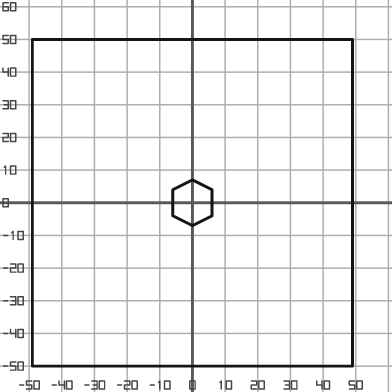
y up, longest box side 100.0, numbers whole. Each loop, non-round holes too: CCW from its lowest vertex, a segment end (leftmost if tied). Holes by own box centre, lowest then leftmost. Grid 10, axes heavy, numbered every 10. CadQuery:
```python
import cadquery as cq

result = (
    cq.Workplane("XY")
    .moveTo(-49.0, -50.0)
    .lineTo(49.0, -50.0)
    .lineTo(49.0, 50.0)
    .lineTo(-49.0, 50.0)
    .close()
    .moveTo(0.0, -7.0)
    .lineTo(6.0, -4.0)
    .lineTo(6.0, 4.0)
    .lineTo(0.0, 7.0)
    .lineTo(-6.0, 4.0)
    .lineTo(-6.0, -4.0)
    .close()
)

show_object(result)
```